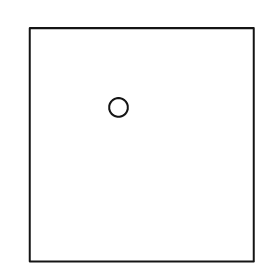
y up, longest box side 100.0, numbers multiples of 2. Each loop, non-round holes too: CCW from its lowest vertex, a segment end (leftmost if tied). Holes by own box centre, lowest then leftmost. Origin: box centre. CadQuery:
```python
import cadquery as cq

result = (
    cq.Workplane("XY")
    .moveTo(-48.0, -50.0)
    .lineTo(48.0, -50.0)
    .lineTo(48.0, 50.0)
    .lineTo(-48.0, 50.0)
    .close()
    .moveTo(-10.0, 16.0)
    .circle(4.0)
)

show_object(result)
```